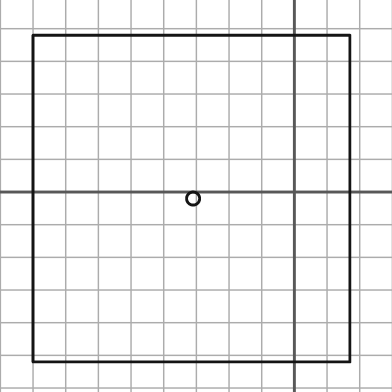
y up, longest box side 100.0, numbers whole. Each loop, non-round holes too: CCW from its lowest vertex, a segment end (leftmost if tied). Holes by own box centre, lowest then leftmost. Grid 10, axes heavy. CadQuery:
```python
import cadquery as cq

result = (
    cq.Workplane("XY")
    .moveTo(-80.0, -52.0)
    .lineTo(17.0, -52.0)
    .lineTo(17.0, 48.0)
    .lineTo(-80.0, 48.0)
    .close()
    .moveTo(-31.0, -2.0)
    .circle(2.0)
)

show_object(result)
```